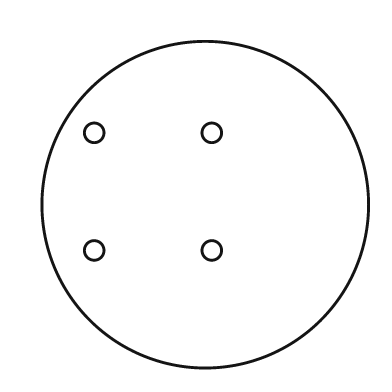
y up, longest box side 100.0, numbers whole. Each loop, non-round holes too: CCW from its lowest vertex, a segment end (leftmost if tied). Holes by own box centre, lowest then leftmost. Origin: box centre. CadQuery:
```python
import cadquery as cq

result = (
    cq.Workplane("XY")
    .moveTo(0.0, 0.0)
    .circle(50.0)
    .moveTo(-34.0, -14.0)
    .circle(3.0)
    .moveTo(2.0, -14.0)
    .circle(3.0)
    .moveTo(-34.0, 22.0)
    .circle(3.0)
    .moveTo(2.0, 22.0)
    .circle(3.0)
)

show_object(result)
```